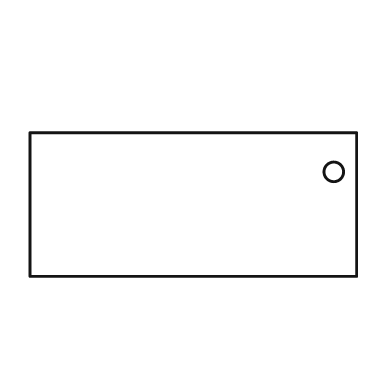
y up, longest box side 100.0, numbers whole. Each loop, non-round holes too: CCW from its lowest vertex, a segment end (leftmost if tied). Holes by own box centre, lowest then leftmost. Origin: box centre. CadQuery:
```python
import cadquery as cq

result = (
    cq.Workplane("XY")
    .moveTo(-50.0, -22.0)
    .lineTo(50.0, -22.0)
    .lineTo(50.0, 22.0)
    .lineTo(-50.0, 22.0)
    .close()
    .moveTo(43.0, 10.0)
    .circle(3.0)
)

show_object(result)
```